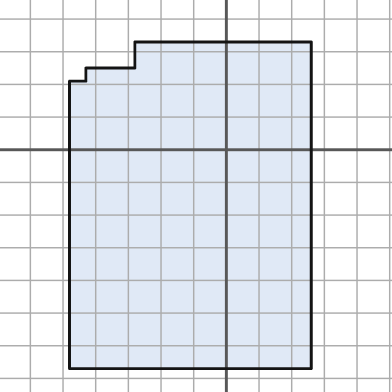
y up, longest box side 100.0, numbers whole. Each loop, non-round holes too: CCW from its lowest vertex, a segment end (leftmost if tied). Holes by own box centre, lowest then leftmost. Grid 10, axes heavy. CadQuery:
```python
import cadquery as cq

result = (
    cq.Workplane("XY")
    .moveTo(-48.0, -67.0)
    .lineTo(26.0, -67.0)
    .lineTo(26.0, 33.0)
    .lineTo(-28.0, 33.0)
    .lineTo(-28.0, 25.0)
    .lineTo(-43.0, 25.0)
    .lineTo(-43.0, 21.0)
    .lineTo(-48.0, 21.0)
    .close()
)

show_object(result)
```